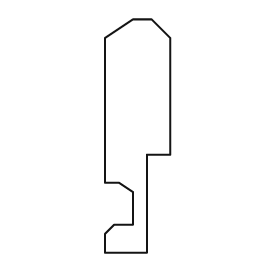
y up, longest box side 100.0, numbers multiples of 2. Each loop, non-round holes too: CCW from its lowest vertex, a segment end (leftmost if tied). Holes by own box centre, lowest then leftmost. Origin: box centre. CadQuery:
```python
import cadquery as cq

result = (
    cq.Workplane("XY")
    .moveTo(-14.0, -50.0)
    .lineTo(4.0, -50.0)
    .lineTo(4.0, -8.0)
    .lineTo(14.0, -8.0)
    .lineTo(14.0, 42.0)
    .lineTo(6.0, 50.0)
    .lineTo(-2.0, 50.0)
    .lineTo(-14.0, 42.0)
    .lineTo(-14.0, -20.0)
    .lineTo(-8.0, -20.0)
    .lineTo(-2.0, -24.0)
    .lineTo(-2.0, -38.0)
    .lineTo(-10.0, -38.0)
    .lineTo(-14.0, -42.0)
    .close()
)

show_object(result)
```